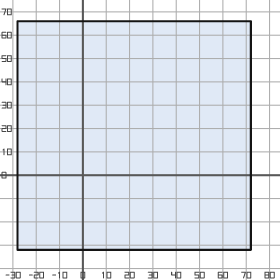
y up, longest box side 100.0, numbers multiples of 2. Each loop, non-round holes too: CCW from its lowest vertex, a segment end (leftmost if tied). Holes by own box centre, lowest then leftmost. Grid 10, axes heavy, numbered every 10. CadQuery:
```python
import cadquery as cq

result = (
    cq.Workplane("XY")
    .moveTo(-28.0, -32.0)
    .lineTo(72.0, -32.0)
    .lineTo(72.0, 66.0)
    .lineTo(-28.0, 66.0)
    .close()
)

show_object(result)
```